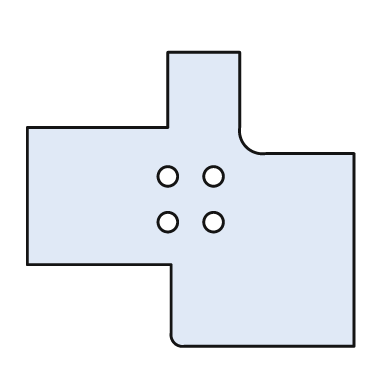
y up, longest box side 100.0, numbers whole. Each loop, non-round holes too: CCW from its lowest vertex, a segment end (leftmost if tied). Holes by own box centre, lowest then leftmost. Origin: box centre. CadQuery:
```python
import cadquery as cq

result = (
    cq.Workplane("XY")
    .moveTo(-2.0, -45.0)
    .lineTo(50.0, -45.0)
    .lineTo(50.0, 14.0)
    .lineTo(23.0, 14.0)
    .threePointArc((17.0, 16.0), (15.0, 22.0))
    .lineTo(15.0, 45.0)
    .lineTo(-7.0, 45.0)
    .lineTo(-7.0, 22.0)
    .lineTo(-50.0, 22.0)
    .lineTo(-50.0, -20.0)
    .lineTo(-6.0, -20.0)
    .lineTo(-6.0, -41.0)
    .threePointArc((-5.0, -44.0), (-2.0, -45.0))
    .close()
    .moveTo(-7.0, -7.0)
    .circle(3.0)
    .moveTo(7.0, -7.0)
    .circle(3.0)
    .moveTo(-7.0, 7.0)
    .circle(3.0)
    .moveTo(7.0, 7.0)
    .circle(3.0)
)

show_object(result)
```